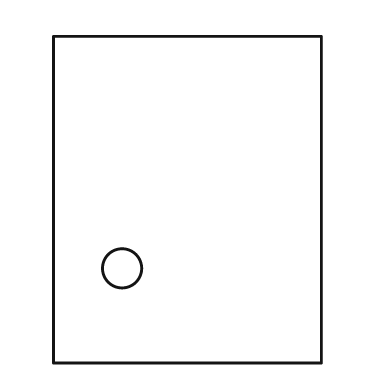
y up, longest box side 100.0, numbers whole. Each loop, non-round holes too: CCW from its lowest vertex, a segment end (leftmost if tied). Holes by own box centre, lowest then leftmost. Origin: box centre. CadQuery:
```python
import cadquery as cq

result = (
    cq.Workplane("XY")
    .moveTo(-41.0, -50.0)
    .lineTo(41.0, -50.0)
    .lineTo(41.0, 50.0)
    .lineTo(-41.0, 50.0)
    .close()
    .moveTo(-20.0, -21.0)
    .circle(6.0)
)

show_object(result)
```